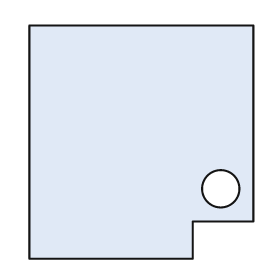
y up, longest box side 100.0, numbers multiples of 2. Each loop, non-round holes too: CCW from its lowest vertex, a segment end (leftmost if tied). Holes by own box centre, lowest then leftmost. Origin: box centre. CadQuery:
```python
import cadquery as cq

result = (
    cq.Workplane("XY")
    .moveTo(-48.0, -50.0)
    .lineTo(22.0, -50.0)
    .lineTo(22.0, -34.0)
    .lineTo(48.0, -34.0)
    .lineTo(48.0, 50.0)
    .lineTo(-48.0, 50.0)
    .close()
    .moveTo(34.0, -20.0)
    .circle(8.0)
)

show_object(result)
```